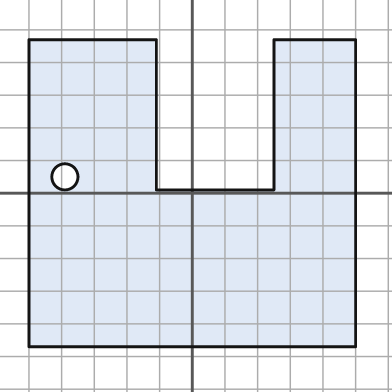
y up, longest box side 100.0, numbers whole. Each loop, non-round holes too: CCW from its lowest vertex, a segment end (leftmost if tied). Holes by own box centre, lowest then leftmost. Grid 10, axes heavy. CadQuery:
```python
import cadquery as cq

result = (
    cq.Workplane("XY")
    .moveTo(-50.0, -47.0)
    .lineTo(50.0, -47.0)
    .lineTo(50.0, 47.0)
    .lineTo(25.0, 47.0)
    .lineTo(25.0, 1.0)
    .lineTo(-11.0, 1.0)
    .lineTo(-11.0, 47.0)
    .lineTo(-50.0, 47.0)
    .close()
    .moveTo(-39.0, 5.0)
    .circle(4.0)
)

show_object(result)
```